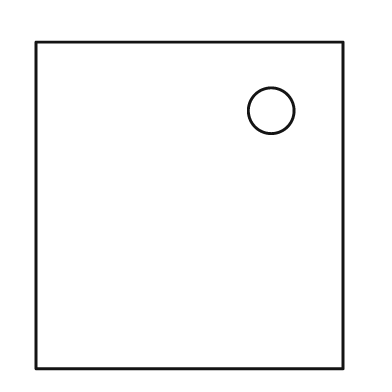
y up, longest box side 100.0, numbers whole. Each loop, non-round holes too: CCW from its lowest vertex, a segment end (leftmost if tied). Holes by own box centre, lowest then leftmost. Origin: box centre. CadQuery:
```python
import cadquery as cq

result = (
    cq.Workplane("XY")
    .moveTo(-47.0, -50.0)
    .lineTo(47.0, -50.0)
    .lineTo(47.0, 50.0)
    .lineTo(-47.0, 50.0)
    .close()
    .moveTo(25.0, 29.0)
    .circle(7.0)
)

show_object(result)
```